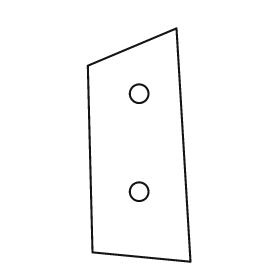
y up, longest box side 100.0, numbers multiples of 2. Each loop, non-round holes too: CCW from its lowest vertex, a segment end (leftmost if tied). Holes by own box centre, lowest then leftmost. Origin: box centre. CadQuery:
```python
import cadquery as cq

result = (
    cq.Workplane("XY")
    .moveTo(22.0, -50.0)
    .lineTo(16.0, 50.0)
    .lineTo(-22.0, 34.0)
    .lineTo(-20.0, -46.0)
    .close()
    .moveTo(0.0, -20.0)
    .circle(4.0)
    .moveTo(0.0, 22.0)
    .circle(4.0)
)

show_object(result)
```